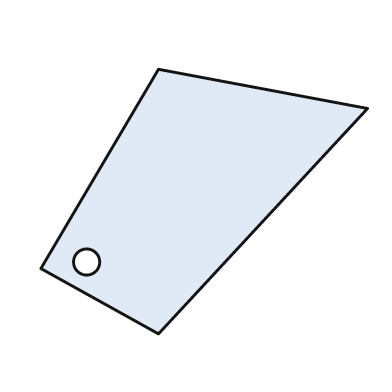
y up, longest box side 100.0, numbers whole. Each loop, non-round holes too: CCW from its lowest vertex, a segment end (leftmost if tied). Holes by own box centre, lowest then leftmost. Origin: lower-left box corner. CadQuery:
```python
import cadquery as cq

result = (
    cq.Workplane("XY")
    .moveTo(36.0, 0.0)
    .lineTo(100.0, 69.0)
    .lineTo(36.0, 81.0)
    .lineTo(0.0, 20.0)
    .close()
    .moveTo(14.0, 22.0)
    .circle(4.0)
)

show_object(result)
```